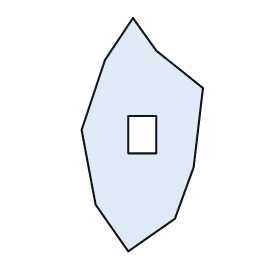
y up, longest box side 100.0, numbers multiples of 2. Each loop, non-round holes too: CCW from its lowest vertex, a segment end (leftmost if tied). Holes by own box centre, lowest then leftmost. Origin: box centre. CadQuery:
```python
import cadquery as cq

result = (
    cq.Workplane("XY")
    .moveTo(-6.0, -50.0)
    .lineTo(14.0, -36.0)
    .lineTo(22.0, -14.0)
    .lineTo(26.0, 20.0)
    .lineTo(6.0, 36.0)
    .lineTo(-4.0, 50.0)
    .lineTo(-16.0, 32.0)
    .lineTo(-26.0, 2.0)
    .lineTo(-20.0, -30.0)
    .close()
    .moveTo(-6.0, -8.0)
    .lineTo(6.0, -8.0)
    .lineTo(6.0, 8.0)
    .lineTo(-6.0, 8.0)
    .close()
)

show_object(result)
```